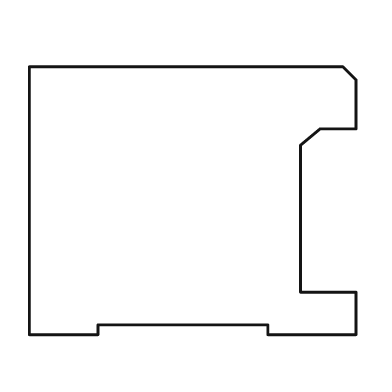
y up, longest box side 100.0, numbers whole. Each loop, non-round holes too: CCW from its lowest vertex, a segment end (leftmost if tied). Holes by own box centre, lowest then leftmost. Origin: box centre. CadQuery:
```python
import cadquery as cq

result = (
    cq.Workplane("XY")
    .moveTo(-50.0, -41.0)
    .lineTo(-29.0, -41.0)
    .lineTo(-29.0, -38.0)
    .lineTo(23.0, -38.0)
    .lineTo(23.0, -41.0)
    .lineTo(50.0, -41.0)
    .lineTo(50.0, -28.0)
    .lineTo(33.0, -28.0)
    .lineTo(33.0, 17.0)
    .lineTo(39.0, 22.0)
    .lineTo(50.0, 22.0)
    .lineTo(50.0, 37.0)
    .lineTo(46.0, 41.0)
    .lineTo(-50.0, 41.0)
    .close()
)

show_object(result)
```